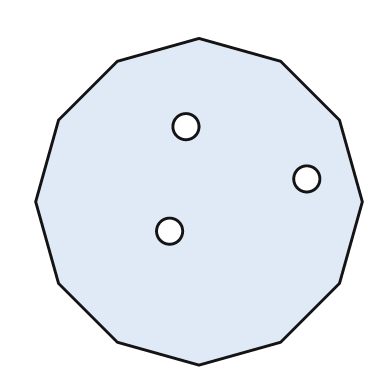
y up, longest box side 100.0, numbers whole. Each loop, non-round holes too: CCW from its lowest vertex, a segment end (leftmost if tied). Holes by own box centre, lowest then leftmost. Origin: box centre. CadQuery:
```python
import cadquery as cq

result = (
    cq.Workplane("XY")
    .moveTo(0.0, -50.0)
    .lineTo(25.0, -43.0)
    .lineTo(43.0, -25.0)
    .lineTo(50.0, 0.0)
    .lineTo(43.0, 25.0)
    .lineTo(25.0, 43.0)
    .lineTo(0.0, 50.0)
    .lineTo(-25.0, 43.0)
    .lineTo(-43.0, 25.0)
    .lineTo(-50.0, 0.0)
    .lineTo(-43.0, -25.0)
    .lineTo(-25.0, -43.0)
    .close()
    .moveTo(-9.0, -9.0)
    .circle(4.0)
    .moveTo(33.0, 7.0)
    .circle(4.0)
    .moveTo(-4.0, 23.0)
    .circle(4.0)
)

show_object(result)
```